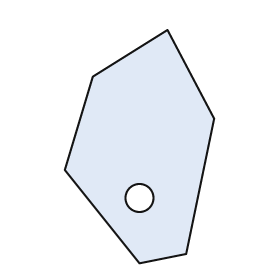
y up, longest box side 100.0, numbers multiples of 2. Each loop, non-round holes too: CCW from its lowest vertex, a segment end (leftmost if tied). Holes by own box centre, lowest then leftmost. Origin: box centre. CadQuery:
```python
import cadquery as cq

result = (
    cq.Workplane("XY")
    .moveTo(0.0, -50.0)
    .lineTo(20.0, -46.0)
    .lineTo(32.0, 12.0)
    .lineTo(12.0, 50.0)
    .lineTo(-20.0, 30.0)
    .lineTo(-32.0, -10.0)
    .close()
    .moveTo(0.0, -22.0)
    .circle(6.0)
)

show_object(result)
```